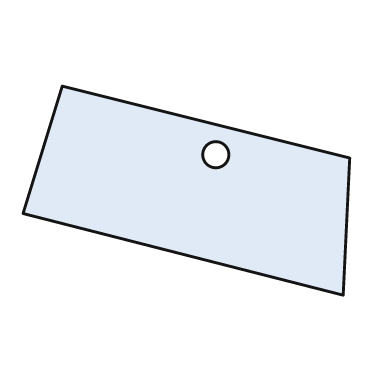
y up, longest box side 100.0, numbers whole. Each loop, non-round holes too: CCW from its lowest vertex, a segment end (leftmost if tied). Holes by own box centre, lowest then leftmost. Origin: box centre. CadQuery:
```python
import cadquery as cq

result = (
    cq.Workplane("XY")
    .moveTo(48.0, -32.0)
    .lineTo(50.0, 10.0)
    .lineTo(-38.0, 32.0)
    .lineTo(-50.0, -7.0)
    .close()
    .moveTo(9.0, 11.0)
    .circle(4.0)
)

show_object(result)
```